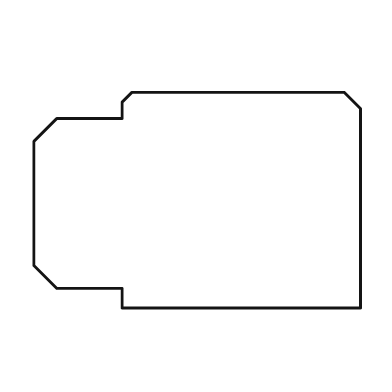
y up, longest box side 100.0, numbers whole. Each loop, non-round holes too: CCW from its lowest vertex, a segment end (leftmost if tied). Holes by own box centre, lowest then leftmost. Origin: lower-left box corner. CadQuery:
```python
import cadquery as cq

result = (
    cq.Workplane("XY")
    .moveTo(27.0, 0.0)
    .lineTo(100.0, 0.0)
    .lineTo(100.0, 61.0)
    .lineTo(95.0, 66.0)
    .lineTo(30.0, 66.0)
    .lineTo(27.0, 63.0)
    .lineTo(27.0, 58.0)
    .lineTo(7.0, 58.0)
    .lineTo(0.0, 51.0)
    .lineTo(0.0, 13.0)
    .lineTo(7.0, 6.0)
    .lineTo(27.0, 6.0)
    .close()
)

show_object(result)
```